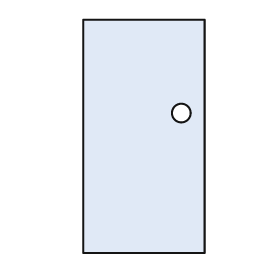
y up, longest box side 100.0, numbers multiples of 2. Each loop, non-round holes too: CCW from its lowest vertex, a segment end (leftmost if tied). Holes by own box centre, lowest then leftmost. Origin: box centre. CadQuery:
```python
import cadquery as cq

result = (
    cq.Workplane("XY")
    .moveTo(-26.0, -50.0)
    .lineTo(26.0, -50.0)
    .lineTo(26.0, 50.0)
    .lineTo(-26.0, 50.0)
    .close()
    .moveTo(16.0, 10.0)
    .circle(4.0)
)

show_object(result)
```